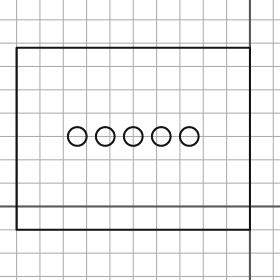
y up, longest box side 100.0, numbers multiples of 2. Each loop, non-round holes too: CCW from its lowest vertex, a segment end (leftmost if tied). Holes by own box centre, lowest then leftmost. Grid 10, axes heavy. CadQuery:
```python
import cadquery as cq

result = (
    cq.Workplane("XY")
    .moveTo(-100.0, -10.0)
    .lineTo(0.0, -10.0)
    .lineTo(0.0, 68.0)
    .lineTo(-100.0, 68.0)
    .close()
    .moveTo(-74.0, 30.0)
    .circle(4.0)
    .moveTo(-62.0, 30.0)
    .circle(4.0)
    .moveTo(-50.0, 30.0)
    .circle(4.0)
    .moveTo(-38.0, 30.0)
    .circle(4.0)
    .moveTo(-26.0, 30.0)
    .circle(4.0)
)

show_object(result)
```